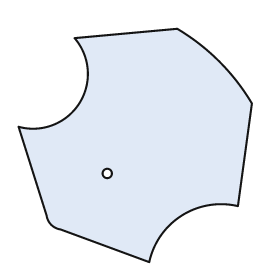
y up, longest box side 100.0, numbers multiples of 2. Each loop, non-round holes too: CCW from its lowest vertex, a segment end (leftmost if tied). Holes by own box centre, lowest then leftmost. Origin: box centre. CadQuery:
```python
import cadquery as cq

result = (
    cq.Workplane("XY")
    .moveTo(6.0, -50.0)
    .threePointArc((20.0, -30.0), (44.0, -26.0))
    .lineTo(50.0, 18.0)
    .threePointArc((36.0, 36.0), (18.0, 50.0))
    .lineTo(-26.0, 46.0)
    .threePointArc((-24.0, 18.0), (-50.0, 8.0))
    .lineTo(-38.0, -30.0)
    .threePointArc((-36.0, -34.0), (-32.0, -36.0))
    .close()
    .moveTo(-12.0, -12.0)
    .circle(2.0)
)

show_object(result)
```